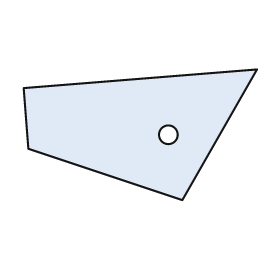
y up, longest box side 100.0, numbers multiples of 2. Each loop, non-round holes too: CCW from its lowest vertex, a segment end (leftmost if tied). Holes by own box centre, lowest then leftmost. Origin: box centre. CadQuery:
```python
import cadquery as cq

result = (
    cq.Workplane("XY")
    .moveTo(18.0, -28.0)
    .lineTo(50.0, 28.0)
    .lineTo(-50.0, 20.0)
    .lineTo(-48.0, -6.0)
    .close()
    .moveTo(12.0, 0.0)
    .circle(4.0)
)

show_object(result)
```